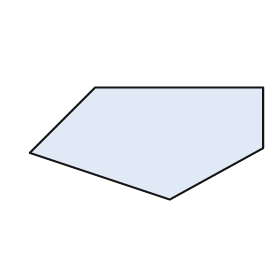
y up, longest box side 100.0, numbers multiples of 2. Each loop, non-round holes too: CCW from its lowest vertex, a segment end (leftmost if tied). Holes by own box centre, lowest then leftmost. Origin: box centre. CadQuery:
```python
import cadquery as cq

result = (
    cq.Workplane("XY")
    .moveTo(10.0, -24.0)
    .lineTo(50.0, -2.0)
    .lineTo(50.0, 24.0)
    .lineTo(-22.0, 24.0)
    .lineTo(-50.0, -4.0)
    .close()
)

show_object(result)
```